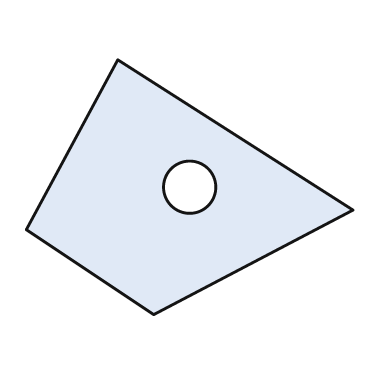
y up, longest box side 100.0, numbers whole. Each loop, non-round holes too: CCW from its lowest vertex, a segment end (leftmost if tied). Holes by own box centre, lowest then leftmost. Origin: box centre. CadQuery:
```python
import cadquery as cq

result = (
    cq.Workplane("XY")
    .moveTo(-11.0, -39.0)
    .lineTo(50.0, -7.0)
    .lineTo(-22.0, 39.0)
    .lineTo(-50.0, -13.0)
    .close()
    .moveTo(0.0, 0.0)
    .circle(8.0)
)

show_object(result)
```